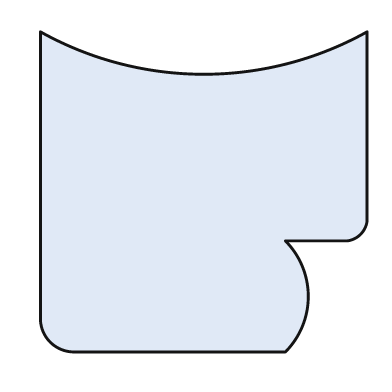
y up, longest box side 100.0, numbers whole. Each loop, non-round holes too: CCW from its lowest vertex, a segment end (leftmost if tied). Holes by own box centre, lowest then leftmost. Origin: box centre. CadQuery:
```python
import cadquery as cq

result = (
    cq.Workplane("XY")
    .moveTo(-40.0, -49.0)
    .lineTo(25.0, -49.0)
    .threePointArc((32.0, -32.0), (25.0, -15.0))
    .lineTo(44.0, -15.0)
    .threePointArc((48.0, -13.0), (50.0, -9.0))
    .lineTo(50.0, 49.0)
    .threePointArc((0.0, 36.0), (-50.0, 49.0))
    .lineTo(-50.0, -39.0)
    .threePointArc((-47.0, -46.0), (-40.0, -49.0))
    .close()
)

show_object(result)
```